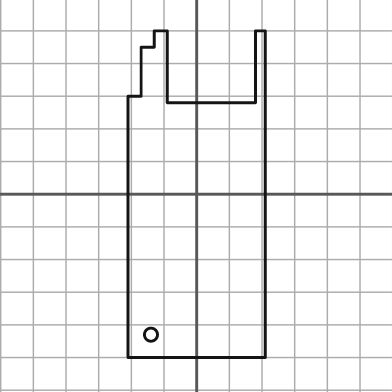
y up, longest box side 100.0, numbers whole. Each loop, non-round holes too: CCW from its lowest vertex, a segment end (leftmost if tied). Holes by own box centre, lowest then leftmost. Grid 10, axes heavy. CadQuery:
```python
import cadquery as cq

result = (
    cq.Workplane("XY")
    .moveTo(-21.0, -50.0)
    .lineTo(21.0, -50.0)
    .lineTo(21.0, 50.0)
    .lineTo(18.0, 50.0)
    .lineTo(18.0, 28.0)
    .lineTo(-9.0, 28.0)
    .lineTo(-9.0, 50.0)
    .lineTo(-13.0, 50.0)
    .lineTo(-13.0, 45.0)
    .lineTo(-17.0, 45.0)
    .lineTo(-17.0, 30.0)
    .lineTo(-21.0, 30.0)
    .close()
    .moveTo(-14.0, -43.0)
    .circle(2.0)
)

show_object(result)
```